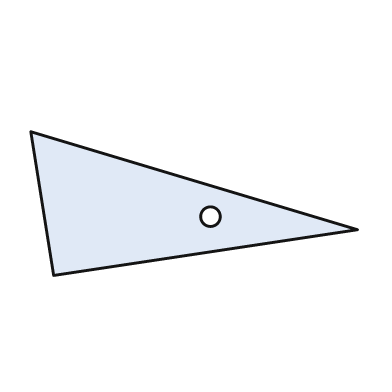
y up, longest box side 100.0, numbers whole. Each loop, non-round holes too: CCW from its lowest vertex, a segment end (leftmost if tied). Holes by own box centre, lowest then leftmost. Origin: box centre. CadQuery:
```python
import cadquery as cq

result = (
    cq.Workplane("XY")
    .moveTo(-43.0, -22.0)
    .lineTo(50.0, -8.0)
    .lineTo(-50.0, 22.0)
    .close()
    .moveTo(5.0, -4.0)
    .circle(3.0)
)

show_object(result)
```